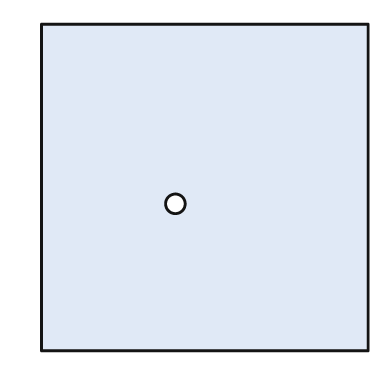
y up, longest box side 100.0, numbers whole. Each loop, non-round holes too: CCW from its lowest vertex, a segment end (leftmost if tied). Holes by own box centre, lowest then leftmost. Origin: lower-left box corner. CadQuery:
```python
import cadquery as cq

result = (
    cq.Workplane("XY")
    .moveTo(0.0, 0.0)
    .lineTo(100.0, 0.0)
    .lineTo(100.0, 100.0)
    .lineTo(0.0, 100.0)
    .close()
    .moveTo(41.0, 45.0)
    .circle(3.0)
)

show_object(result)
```